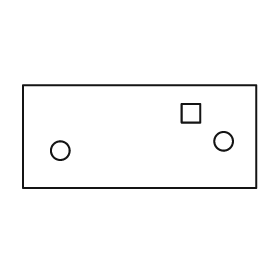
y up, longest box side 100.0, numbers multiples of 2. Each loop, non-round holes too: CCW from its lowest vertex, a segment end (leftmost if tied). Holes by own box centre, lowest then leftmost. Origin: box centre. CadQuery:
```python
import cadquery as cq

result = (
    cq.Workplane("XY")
    .moveTo(-50.0, -22.0)
    .lineTo(50.0, -22.0)
    .lineTo(50.0, 22.0)
    .lineTo(-50.0, 22.0)
    .close()
    .moveTo(-34.0, -6.0)
    .circle(4.0)
    .moveTo(36.0, -2.0)
    .circle(4.0)
    .moveTo(18.0, 6.0)
    .lineTo(26.0, 6.0)
    .lineTo(26.0, 14.0)
    .lineTo(18.0, 14.0)
    .close()
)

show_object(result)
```